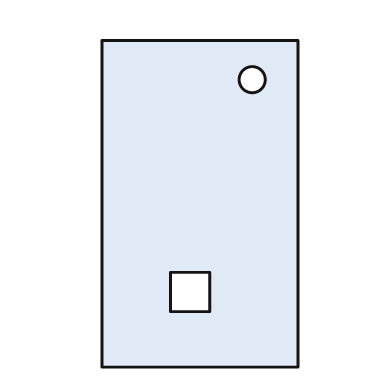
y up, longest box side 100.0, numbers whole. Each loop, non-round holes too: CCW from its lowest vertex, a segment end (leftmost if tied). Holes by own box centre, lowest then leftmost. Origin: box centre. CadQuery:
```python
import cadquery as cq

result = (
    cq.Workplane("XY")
    .moveTo(-30.0, -50.0)
    .lineTo(30.0, -50.0)
    .lineTo(30.0, 50.0)
    .lineTo(-30.0, 50.0)
    .close()
    .moveTo(-9.0, -33.0)
    .lineTo(3.0, -33.0)
    .lineTo(3.0, -21.0)
    .lineTo(-9.0, -21.0)
    .close()
    .moveTo(16.0, 38.0)
    .circle(4.0)
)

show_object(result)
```